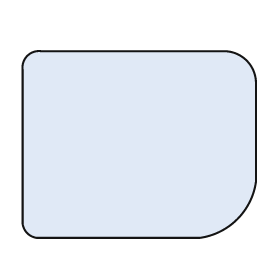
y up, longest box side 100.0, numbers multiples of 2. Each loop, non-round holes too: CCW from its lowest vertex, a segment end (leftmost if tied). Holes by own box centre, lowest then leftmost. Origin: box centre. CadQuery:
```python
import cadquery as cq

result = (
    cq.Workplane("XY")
    .moveTo(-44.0, -40.0)
    .lineTo(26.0, -40.0)
    .threePointArc((42.0, -32.0), (50.0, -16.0))
    .lineTo(50.0, 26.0)
    .threePointArc((46.0, 36.0), (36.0, 40.0))
    .lineTo(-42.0, 40.0)
    .threePointArc((-48.0, 38.0), (-50.0, 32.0))
    .lineTo(-50.0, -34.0)
    .threePointArc((-48.0, -38.0), (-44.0, -40.0))
    .close()
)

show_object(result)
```